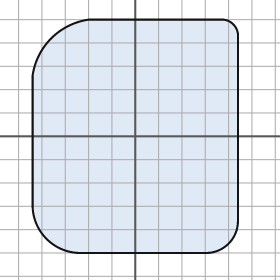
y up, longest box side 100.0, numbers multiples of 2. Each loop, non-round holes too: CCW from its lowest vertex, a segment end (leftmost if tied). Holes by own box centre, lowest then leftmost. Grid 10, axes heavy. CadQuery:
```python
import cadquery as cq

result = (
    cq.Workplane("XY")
    .moveTo(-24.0, -50.0)
    .lineTo(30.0, -50.0)
    .threePointArc((40.0, -46.0), (44.0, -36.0))
    .lineTo(44.0, 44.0)
    .threePointArc((42.0, 48.0), (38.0, 50.0))
    .lineTo(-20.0, 50.0)
    .threePointArc((-36.0, 42.0), (-44.0, 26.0))
    .lineTo(-44.0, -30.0)
    .threePointArc((-38.0, -44.0), (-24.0, -50.0))
    .close()
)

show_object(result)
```